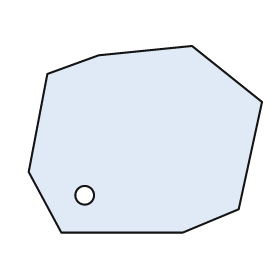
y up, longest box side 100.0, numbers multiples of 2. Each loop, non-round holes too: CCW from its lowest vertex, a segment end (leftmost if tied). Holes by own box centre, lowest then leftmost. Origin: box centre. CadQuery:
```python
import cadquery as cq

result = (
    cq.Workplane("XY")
    .moveTo(-36.0, -40.0)
    .lineTo(16.0, -40.0)
    .lineTo(40.0, -30.0)
    .lineTo(50.0, 16.0)
    .lineTo(20.0, 40.0)
    .lineTo(-20.0, 36.0)
    .lineTo(-42.0, 28.0)
    .lineTo(-50.0, -14.0)
    .close()
    .moveTo(-26.0, -24.0)
    .circle(4.0)
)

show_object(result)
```